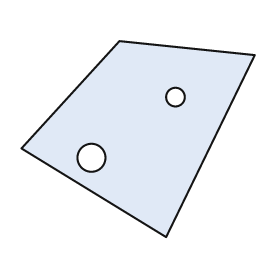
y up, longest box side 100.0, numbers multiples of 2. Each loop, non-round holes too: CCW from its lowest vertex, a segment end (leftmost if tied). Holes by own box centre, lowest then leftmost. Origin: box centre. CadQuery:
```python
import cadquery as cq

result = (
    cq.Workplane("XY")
    .moveTo(12.0, -42.0)
    .lineTo(50.0, 36.0)
    .lineTo(-8.0, 42.0)
    .lineTo(-50.0, -4.0)
    .close()
    .moveTo(-20.0, -8.0)
    .circle(6.0)
    .moveTo(16.0, 18.0)
    .circle(4.0)
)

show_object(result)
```